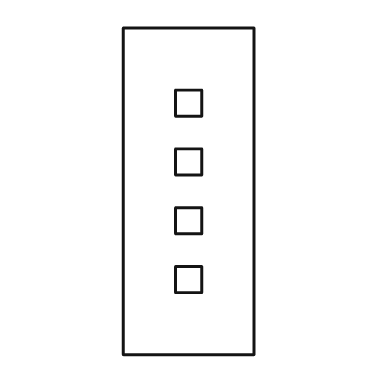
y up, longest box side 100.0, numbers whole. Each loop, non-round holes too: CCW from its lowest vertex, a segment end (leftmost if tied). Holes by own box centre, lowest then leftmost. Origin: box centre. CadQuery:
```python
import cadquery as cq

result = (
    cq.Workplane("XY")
    .moveTo(-20.0, -50.0)
    .lineTo(20.0, -50.0)
    .lineTo(20.0, 50.0)
    .lineTo(-20.0, 50.0)
    .close()
    .moveTo(-4.0, -31.0)
    .lineTo(4.0, -31.0)
    .lineTo(4.0, -23.0)
    .lineTo(-4.0, -23.0)
    .close()
    .moveTo(-4.0, -13.0)
    .lineTo(4.0, -13.0)
    .lineTo(4.0, -5.0)
    .lineTo(-4.0, -5.0)
    .close()
    .moveTo(-4.0, 5.0)
    .lineTo(4.0, 5.0)
    .lineTo(4.0, 13.0)
    .lineTo(-4.0, 13.0)
    .close()
    .moveTo(-4.0, 23.0)
    .lineTo(4.0, 23.0)
    .lineTo(4.0, 31.0)
    .lineTo(-4.0, 31.0)
    .close()
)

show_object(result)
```